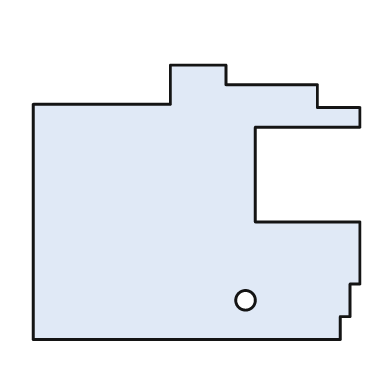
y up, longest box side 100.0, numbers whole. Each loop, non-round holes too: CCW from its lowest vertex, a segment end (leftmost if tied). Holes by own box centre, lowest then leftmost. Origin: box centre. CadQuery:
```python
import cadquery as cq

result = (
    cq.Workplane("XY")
    .moveTo(-50.0, -42.0)
    .lineTo(44.0, -42.0)
    .lineTo(44.0, -35.0)
    .lineTo(47.0, -35.0)
    .lineTo(47.0, -25.0)
    .lineTo(50.0, -25.0)
    .lineTo(50.0, -6.0)
    .lineTo(18.0, -6.0)
    .lineTo(18.0, 23.0)
    .lineTo(50.0, 23.0)
    .lineTo(50.0, 29.0)
    .lineTo(37.0, 29.0)
    .lineTo(37.0, 36.0)
    .lineTo(9.0, 36.0)
    .lineTo(9.0, 42.0)
    .lineTo(-8.0, 42.0)
    .lineTo(-8.0, 30.0)
    .lineTo(-50.0, 30.0)
    .close()
    .moveTo(15.0, -30.0)
    .circle(3.0)
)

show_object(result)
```